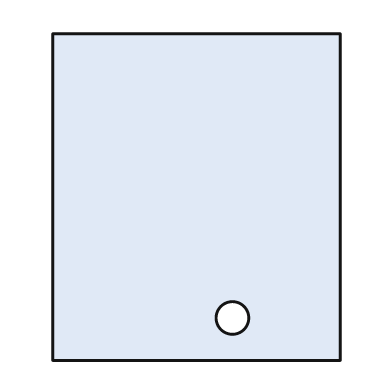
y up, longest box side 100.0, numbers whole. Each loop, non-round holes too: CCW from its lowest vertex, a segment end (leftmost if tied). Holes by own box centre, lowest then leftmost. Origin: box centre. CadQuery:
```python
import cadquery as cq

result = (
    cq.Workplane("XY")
    .moveTo(-44.0, -50.0)
    .lineTo(44.0, -50.0)
    .lineTo(44.0, 50.0)
    .lineTo(-44.0, 50.0)
    .close()
    .moveTo(11.0, -37.0)
    .circle(5.0)
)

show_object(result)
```